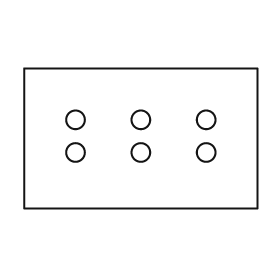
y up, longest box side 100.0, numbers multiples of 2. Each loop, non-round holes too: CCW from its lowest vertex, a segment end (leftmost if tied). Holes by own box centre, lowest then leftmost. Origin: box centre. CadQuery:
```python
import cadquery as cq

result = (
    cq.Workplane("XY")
    .moveTo(-50.0, -30.0)
    .lineTo(50.0, -30.0)
    .lineTo(50.0, 30.0)
    .lineTo(-50.0, 30.0)
    .close()
    .moveTo(-28.0, -6.0)
    .circle(4.0)
    .moveTo(0.0, -6.0)
    .circle(4.0)
    .moveTo(28.0, -6.0)
    .circle(4.0)
    .moveTo(-28.0, 8.0)
    .circle(4.0)
    .moveTo(0.0, 8.0)
    .circle(4.0)
    .moveTo(28.0, 8.0)
    .circle(4.0)
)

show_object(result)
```